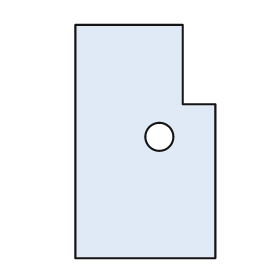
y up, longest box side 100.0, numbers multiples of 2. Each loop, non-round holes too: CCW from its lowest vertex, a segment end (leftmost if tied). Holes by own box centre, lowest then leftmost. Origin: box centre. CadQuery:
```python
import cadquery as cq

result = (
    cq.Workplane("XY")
    .moveTo(-30.0, -50.0)
    .lineTo(30.0, -50.0)
    .lineTo(30.0, 16.0)
    .lineTo(16.0, 16.0)
    .lineTo(16.0, 50.0)
    .lineTo(-30.0, 50.0)
    .close()
    .moveTo(6.0, 2.0)
    .circle(6.0)
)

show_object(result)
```